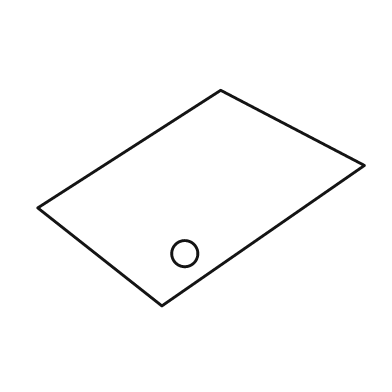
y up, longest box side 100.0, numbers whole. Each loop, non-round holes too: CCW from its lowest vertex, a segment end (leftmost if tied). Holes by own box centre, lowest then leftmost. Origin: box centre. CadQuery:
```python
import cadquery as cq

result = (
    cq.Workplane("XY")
    .moveTo(-12.0, -33.0)
    .lineTo(50.0, 10.0)
    .lineTo(6.0, 33.0)
    .lineTo(-50.0, -3.0)
    .close()
    .moveTo(-5.0, -17.0)
    .circle(4.0)
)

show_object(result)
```